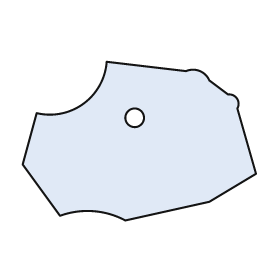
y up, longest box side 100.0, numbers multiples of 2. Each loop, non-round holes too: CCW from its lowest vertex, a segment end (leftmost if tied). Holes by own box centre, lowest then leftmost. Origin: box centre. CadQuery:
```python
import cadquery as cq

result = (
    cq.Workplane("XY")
    .moveTo(-6.0, -34.0)
    .lineTo(30.0, -26.0)
    .lineTo(50.0, -14.0)
    .lineTo(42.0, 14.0)
    .threePointArc((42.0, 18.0), (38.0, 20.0))
    .lineTo(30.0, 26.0)
    .threePointArc((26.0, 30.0), (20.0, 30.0))
    .lineTo(-14.0, 34.0)
    .threePointArc((-24.0, 16.0), (-44.0, 12.0))
    .lineTo(-50.0, -10.0)
    .lineTo(-34.0, -32.0)
    .threePointArc((-20.0, -30.0), (-6.0, -34.0))
    .close()
    .moveTo(-2.0, 10.0)
    .circle(4.0)
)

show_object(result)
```